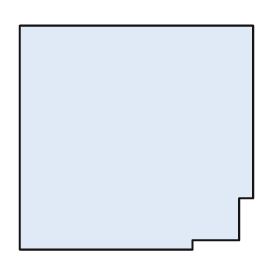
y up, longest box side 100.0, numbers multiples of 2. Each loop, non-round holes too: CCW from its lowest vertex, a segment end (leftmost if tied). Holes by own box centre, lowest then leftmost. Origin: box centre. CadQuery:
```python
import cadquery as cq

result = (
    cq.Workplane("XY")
    .moveTo(-50.0, -48.0)
    .lineTo(24.0, -48.0)
    .lineTo(24.0, -44.0)
    .lineTo(44.0, -44.0)
    .lineTo(44.0, -26.0)
    .lineTo(50.0, -26.0)
    .lineTo(50.0, 48.0)
    .lineTo(-50.0, 48.0)
    .close()
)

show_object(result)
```